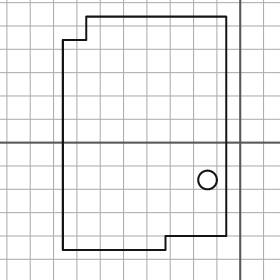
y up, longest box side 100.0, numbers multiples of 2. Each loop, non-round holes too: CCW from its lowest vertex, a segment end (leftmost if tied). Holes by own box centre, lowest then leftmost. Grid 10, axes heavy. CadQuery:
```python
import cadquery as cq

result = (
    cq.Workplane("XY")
    .moveTo(-76.0, -46.0)
    .lineTo(-32.0, -46.0)
    .lineTo(-32.0, -40.0)
    .lineTo(-6.0, -40.0)
    .lineTo(-6.0, 54.0)
    .lineTo(-66.0, 54.0)
    .lineTo(-66.0, 44.0)
    .lineTo(-76.0, 44.0)
    .close()
    .moveTo(-14.0, -16.0)
    .circle(4.0)
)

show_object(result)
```